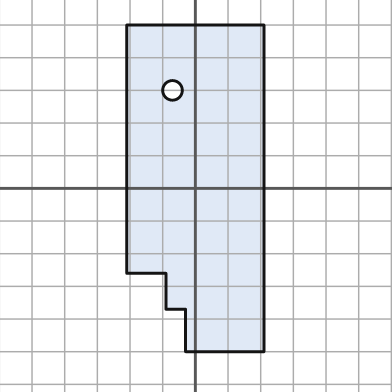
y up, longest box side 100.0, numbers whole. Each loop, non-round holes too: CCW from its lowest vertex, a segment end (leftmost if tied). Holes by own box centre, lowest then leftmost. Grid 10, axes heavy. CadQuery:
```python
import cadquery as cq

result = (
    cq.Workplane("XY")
    .moveTo(-3.0, -50.0)
    .lineTo(21.0, -50.0)
    .lineTo(21.0, 50.0)
    .lineTo(-21.0, 50.0)
    .lineTo(-21.0, -26.0)
    .lineTo(-9.0, -26.0)
    .lineTo(-9.0, -37.0)
    .lineTo(-3.0, -37.0)
    .close()
    .moveTo(-7.0, 30.0)
    .circle(3.0)
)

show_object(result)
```